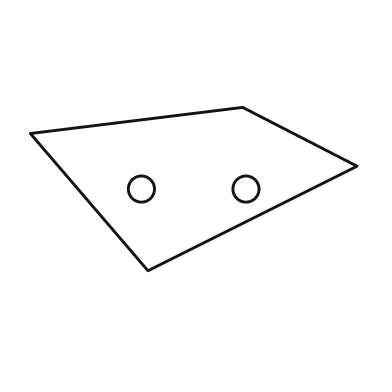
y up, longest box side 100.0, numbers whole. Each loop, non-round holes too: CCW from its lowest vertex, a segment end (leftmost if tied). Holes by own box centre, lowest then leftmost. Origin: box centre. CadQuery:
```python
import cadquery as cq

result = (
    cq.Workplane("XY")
    .moveTo(-14.0, -25.0)
    .lineTo(50.0, 7.0)
    .lineTo(15.0, 25.0)
    .lineTo(-50.0, 17.0)
    .close()
    .moveTo(-16.0, 0.0)
    .circle(4.0)
    .moveTo(16.0, 0.0)
    .circle(4.0)
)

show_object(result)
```